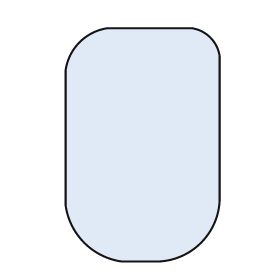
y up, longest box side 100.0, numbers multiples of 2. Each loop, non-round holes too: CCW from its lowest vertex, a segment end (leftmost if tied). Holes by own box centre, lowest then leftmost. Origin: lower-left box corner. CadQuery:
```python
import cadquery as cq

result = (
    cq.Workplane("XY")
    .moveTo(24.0, 0.0)
    .lineTo(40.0, 0.0)
    .threePointArc((58.0, 8.0), (66.0, 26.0))
    .lineTo(66.0, 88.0)
    .threePointArc((62.0, 96.0), (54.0, 100.0))
    .lineTo(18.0, 100.0)
    .threePointArc((6.0, 94.0), (0.0, 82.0))
    .lineTo(0.0, 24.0)
    .threePointArc((8.0, 8.0), (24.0, 0.0))
    .close()
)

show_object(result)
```